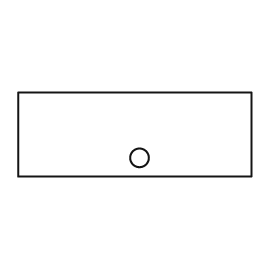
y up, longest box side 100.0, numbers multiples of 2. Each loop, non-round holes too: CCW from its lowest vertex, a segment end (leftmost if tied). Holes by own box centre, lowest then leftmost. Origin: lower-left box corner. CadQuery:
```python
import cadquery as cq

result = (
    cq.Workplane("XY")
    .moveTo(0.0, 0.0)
    .lineTo(100.0, 0.0)
    .lineTo(100.0, 36.0)
    .lineTo(0.0, 36.0)
    .close()
    .moveTo(52.0, 8.0)
    .circle(4.0)
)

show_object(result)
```